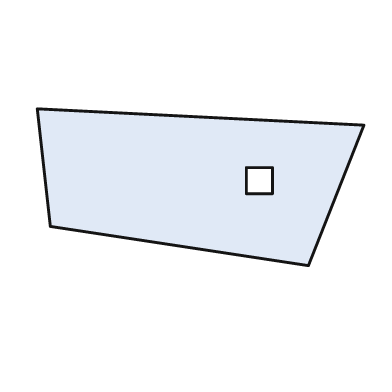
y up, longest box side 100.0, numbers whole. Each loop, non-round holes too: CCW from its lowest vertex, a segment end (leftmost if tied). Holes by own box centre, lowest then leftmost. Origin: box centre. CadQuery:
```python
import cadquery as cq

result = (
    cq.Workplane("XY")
    .moveTo(33.0, -24.0)
    .lineTo(50.0, 19.0)
    .lineTo(-50.0, 24.0)
    .lineTo(-46.0, -12.0)
    .close()
    .moveTo(14.0, -2.0)
    .lineTo(22.0, -2.0)
    .lineTo(22.0, 6.0)
    .lineTo(14.0, 6.0)
    .close()
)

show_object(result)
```